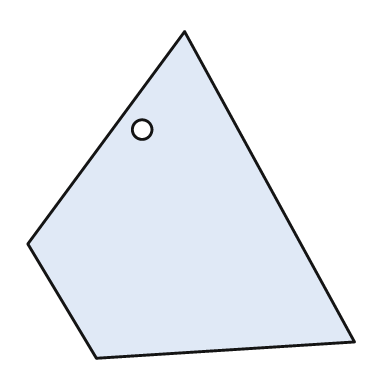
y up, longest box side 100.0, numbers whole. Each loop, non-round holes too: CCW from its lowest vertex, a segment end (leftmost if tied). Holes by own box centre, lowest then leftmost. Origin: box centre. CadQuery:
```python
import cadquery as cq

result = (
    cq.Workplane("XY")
    .moveTo(-29.0, -50.0)
    .lineTo(50.0, -45.0)
    .lineTo(-2.0, 50.0)
    .lineTo(-50.0, -15.0)
    .close()
    .moveTo(-15.0, 20.0)
    .circle(3.0)
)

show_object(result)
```